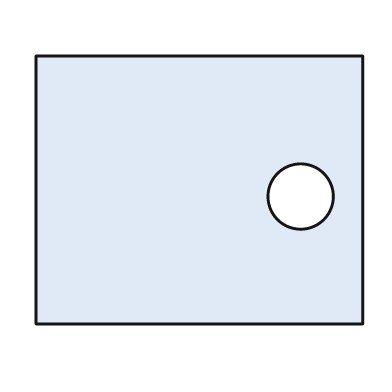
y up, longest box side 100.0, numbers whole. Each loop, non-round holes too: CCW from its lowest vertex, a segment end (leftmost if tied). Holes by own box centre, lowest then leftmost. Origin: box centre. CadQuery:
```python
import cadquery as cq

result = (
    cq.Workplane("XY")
    .moveTo(-50.0, -41.0)
    .lineTo(50.0, -41.0)
    .lineTo(50.0, 41.0)
    .lineTo(-50.0, 41.0)
    .close()
    .moveTo(31.0, -2.0)
    .circle(10.0)
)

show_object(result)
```